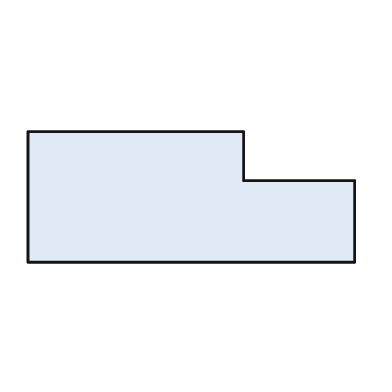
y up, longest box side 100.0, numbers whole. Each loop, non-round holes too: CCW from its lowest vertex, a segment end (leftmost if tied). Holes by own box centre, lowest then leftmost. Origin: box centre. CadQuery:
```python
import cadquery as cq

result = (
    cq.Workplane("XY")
    .moveTo(-50.0, -20.0)
    .lineTo(50.0, -20.0)
    .lineTo(50.0, 5.0)
    .lineTo(16.0, 5.0)
    .lineTo(16.0, 20.0)
    .lineTo(-50.0, 20.0)
    .close()
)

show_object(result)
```